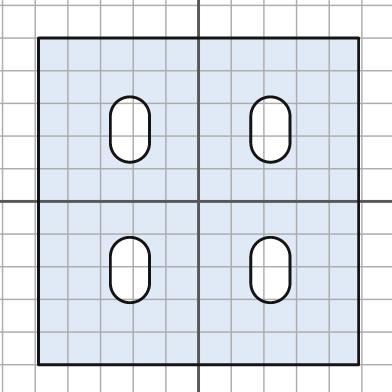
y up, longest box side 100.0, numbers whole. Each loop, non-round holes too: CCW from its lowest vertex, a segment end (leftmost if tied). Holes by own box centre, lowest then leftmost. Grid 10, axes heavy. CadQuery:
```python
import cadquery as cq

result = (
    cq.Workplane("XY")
    .moveTo(-49.0, -50.0)
    .lineTo(49.0, -50.0)
    .lineTo(49.0, 50.0)
    .lineTo(-49.0, 50.0)
    .close()
    .moveTo(-27.0, -25.0)
    .threePointArc((-21.0, -31.0), (-15.0, -25.0))
    .lineTo(-15.0, -17.0)
    .threePointArc((-21.0, -11.0), (-27.0, -17.0))
    .close()
    .moveTo(16.0, -25.0)
    .threePointArc((22.0, -31.0), (28.0, -25.0))
    .lineTo(28.0, -17.0)
    .threePointArc((22.0, -11.0), (16.0, -17.0))
    .close()
    .moveTo(-27.0, 18.0)
    .threePointArc((-21.0, 12.0), (-15.0, 18.0))
    .lineTo(-15.0, 26.0)
    .threePointArc((-21.0, 32.0), (-27.0, 26.0))
    .close()
    .moveTo(16.0, 18.0)
    .threePointArc((22.0, 12.0), (28.0, 18.0))
    .lineTo(28.0, 26.0)
    .threePointArc((22.0, 32.0), (16.0, 26.0))
    .close()
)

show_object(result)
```